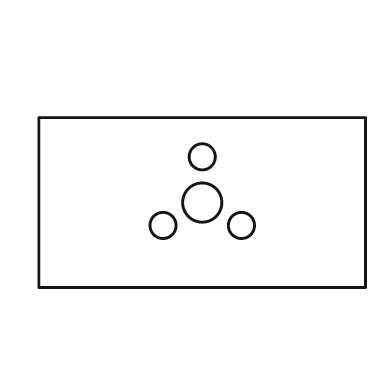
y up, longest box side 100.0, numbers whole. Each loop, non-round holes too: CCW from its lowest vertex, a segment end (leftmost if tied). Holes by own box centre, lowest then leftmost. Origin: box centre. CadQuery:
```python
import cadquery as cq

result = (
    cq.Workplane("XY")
    .moveTo(-50.0, -26.0)
    .lineTo(50.0, -26.0)
    .lineTo(50.0, 26.0)
    .lineTo(-50.0, 26.0)
    .close()
    .moveTo(-12.0, -7.0)
    .circle(4.0)
    .moveTo(12.0, -7.0)
    .circle(4.0)
    .moveTo(0.0, 0.0)
    .circle(6.0)
    .moveTo(0.0, 14.0)
    .circle(4.0)
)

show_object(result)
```